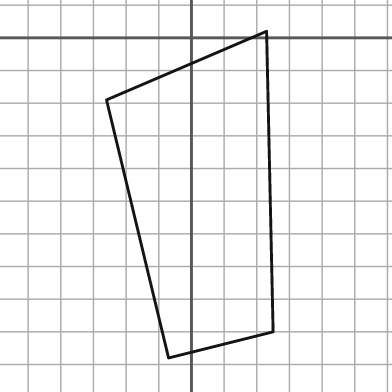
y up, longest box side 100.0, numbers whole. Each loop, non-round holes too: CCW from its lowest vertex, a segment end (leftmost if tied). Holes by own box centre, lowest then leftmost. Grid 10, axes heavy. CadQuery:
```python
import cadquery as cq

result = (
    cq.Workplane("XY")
    .moveTo(-7.0, -98.0)
    .lineTo(25.0, -90.0)
    .lineTo(23.0, 2.0)
    .lineTo(-26.0, -19.0)
    .close()
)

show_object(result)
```